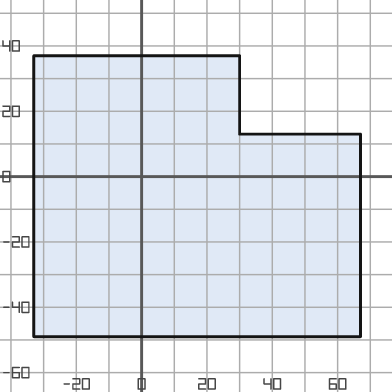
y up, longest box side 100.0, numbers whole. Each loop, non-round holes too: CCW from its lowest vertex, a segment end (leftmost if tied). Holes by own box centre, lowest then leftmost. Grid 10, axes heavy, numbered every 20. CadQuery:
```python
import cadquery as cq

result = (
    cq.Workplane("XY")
    .moveTo(-33.0, -49.0)
    .lineTo(67.0, -49.0)
    .lineTo(67.0, 13.0)
    .lineTo(30.0, 13.0)
    .lineTo(30.0, 37.0)
    .lineTo(-33.0, 37.0)
    .close()
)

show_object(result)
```